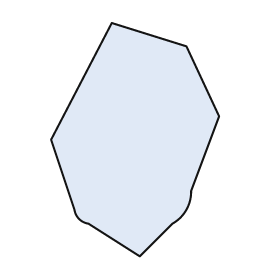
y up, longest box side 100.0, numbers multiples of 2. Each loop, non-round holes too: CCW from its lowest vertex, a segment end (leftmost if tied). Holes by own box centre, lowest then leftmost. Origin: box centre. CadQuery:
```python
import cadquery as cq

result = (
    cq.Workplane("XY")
    .moveTo(2.0, -50.0)
    .lineTo(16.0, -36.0)
    .threePointArc((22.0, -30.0), (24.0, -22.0))
    .lineTo(36.0, 10.0)
    .lineTo(22.0, 40.0)
    .lineTo(-10.0, 50.0)
    .lineTo(-36.0, 0.0)
    .lineTo(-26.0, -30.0)
    .threePointArc((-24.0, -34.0), (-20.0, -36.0))
    .close()
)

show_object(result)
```